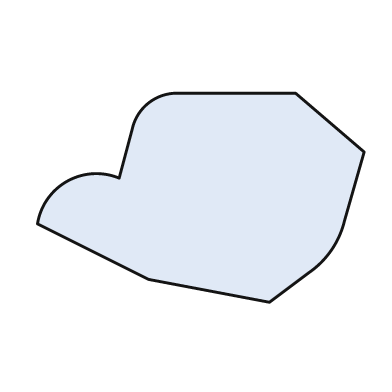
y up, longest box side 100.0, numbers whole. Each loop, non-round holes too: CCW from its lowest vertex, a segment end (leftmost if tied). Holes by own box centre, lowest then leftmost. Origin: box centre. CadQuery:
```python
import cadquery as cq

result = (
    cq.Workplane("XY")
    .moveTo(21.0, -32.0)
    .lineTo(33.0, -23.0)
    .threePointArc((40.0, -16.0), (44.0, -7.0))
    .lineTo(50.0, 14.0)
    .lineTo(29.0, 32.0)
    .lineTo(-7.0, 32.0)
    .threePointArc((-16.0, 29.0), (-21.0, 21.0))
    .lineTo(-25.0, 6.0)
    .threePointArc((-41.0, 5.0), (-50.0, -8.0))
    .lineTo(-16.0, -25.0)
    .close()
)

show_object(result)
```